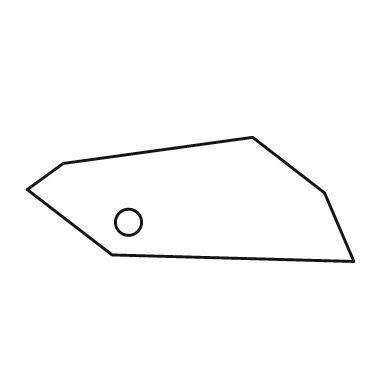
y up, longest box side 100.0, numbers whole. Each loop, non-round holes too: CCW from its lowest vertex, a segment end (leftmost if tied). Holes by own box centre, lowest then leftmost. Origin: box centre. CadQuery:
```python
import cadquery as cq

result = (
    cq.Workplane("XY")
    .moveTo(50.0, -19.0)
    .lineTo(41.0, 2.0)
    .lineTo(19.0, 19.0)
    .lineTo(-39.0, 11.0)
    .lineTo(-50.0, 3.0)
    .lineTo(-24.0, -17.0)
    .close()
    .moveTo(-19.0, -7.0)
    .circle(4.0)
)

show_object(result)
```